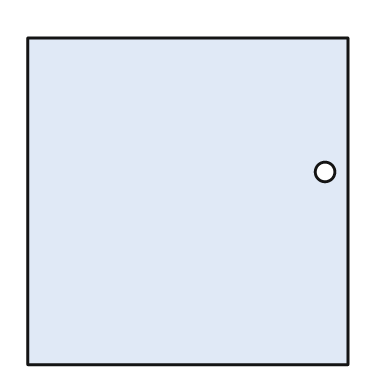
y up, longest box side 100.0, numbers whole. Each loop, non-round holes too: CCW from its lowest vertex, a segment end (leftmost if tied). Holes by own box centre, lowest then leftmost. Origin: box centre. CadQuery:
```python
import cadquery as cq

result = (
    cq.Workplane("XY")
    .moveTo(-49.0, -50.0)
    .lineTo(49.0, -50.0)
    .lineTo(49.0, 50.0)
    .lineTo(-49.0, 50.0)
    .close()
    .moveTo(42.0, 9.0)
    .circle(3.0)
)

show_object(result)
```